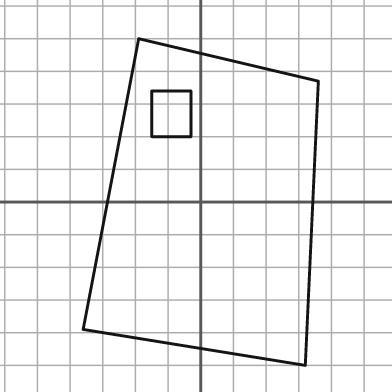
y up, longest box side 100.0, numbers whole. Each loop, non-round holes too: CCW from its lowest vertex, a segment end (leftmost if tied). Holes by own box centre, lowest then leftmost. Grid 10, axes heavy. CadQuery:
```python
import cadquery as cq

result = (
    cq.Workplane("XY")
    .moveTo(32.0, -50.0)
    .lineTo(36.0, 37.0)
    .lineTo(-19.0, 50.0)
    .lineTo(-36.0, -39.0)
    .close()
    .moveTo(-15.0, 20.0)
    .lineTo(-3.0, 20.0)
    .lineTo(-3.0, 34.0)
    .lineTo(-15.0, 34.0)
    .close()
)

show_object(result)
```